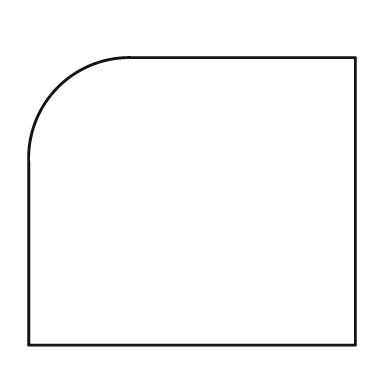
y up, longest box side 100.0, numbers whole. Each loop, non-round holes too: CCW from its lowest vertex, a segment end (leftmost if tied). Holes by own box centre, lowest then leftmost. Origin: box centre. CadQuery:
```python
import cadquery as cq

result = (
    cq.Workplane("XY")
    .moveTo(-50.0, -44.0)
    .lineTo(50.0, -44.0)
    .lineTo(50.0, 44.0)
    .lineTo(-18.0, 44.0)
    .threePointArc((-41.0, 35.0), (-50.0, 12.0))
    .close()
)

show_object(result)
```